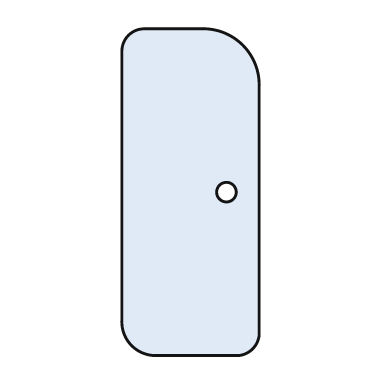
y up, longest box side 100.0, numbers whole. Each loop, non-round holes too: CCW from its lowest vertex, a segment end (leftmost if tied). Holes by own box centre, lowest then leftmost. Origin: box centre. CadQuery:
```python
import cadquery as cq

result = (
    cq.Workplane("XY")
    .moveTo(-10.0, -50.0)
    .lineTo(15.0, -50.0)
    .threePointArc((19.0, -48.0), (21.0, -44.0))
    .lineTo(21.0, 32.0)
    .threePointArc((16.0, 45.0), (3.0, 50.0))
    .lineTo(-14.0, 50.0)
    .threePointArc((-19.0, 48.0), (-21.0, 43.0))
    .lineTo(-21.0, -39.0)
    .threePointArc((-18.0, -47.0), (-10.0, -50.0))
    .close()
    .moveTo(11.0, 0.0)
    .circle(3.0)
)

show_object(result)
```